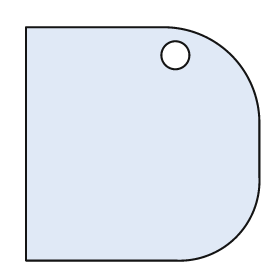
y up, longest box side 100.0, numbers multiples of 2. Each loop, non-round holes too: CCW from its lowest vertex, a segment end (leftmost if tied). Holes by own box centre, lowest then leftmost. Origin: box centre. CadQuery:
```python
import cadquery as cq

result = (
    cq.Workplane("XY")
    .moveTo(-50.0, -50.0)
    .lineTo(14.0, -50.0)
    .threePointArc((40.0, -40.0), (50.0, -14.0))
    .lineTo(50.0, 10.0)
    .threePointArc((38.0, 38.0), (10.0, 50.0))
    .lineTo(-50.0, 50.0)
    .close()
    .moveTo(14.0, 38.0)
    .circle(6.0)
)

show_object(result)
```